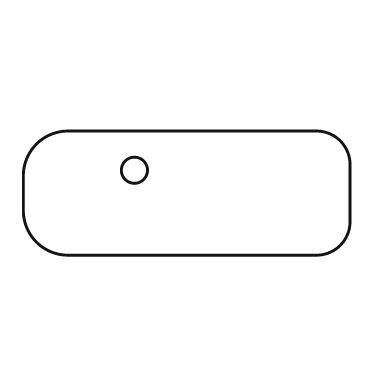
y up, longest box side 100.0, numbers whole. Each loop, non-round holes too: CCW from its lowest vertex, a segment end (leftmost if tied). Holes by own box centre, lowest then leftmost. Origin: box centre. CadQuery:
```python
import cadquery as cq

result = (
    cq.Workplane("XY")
    .moveTo(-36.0, -19.0)
    .lineTo(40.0, -19.0)
    .threePointArc((47.0, -16.0), (50.0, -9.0))
    .lineTo(50.0, 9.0)
    .threePointArc((47.0, 16.0), (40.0, 19.0))
    .lineTo(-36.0, 19.0)
    .threePointArc((-46.0, 15.0), (-50.0, 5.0))
    .lineTo(-50.0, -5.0)
    .threePointArc((-46.0, -15.0), (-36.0, -19.0))
    .close()
    .moveTo(-16.0, 7.0)
    .circle(4.0)
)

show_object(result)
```